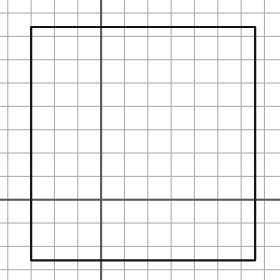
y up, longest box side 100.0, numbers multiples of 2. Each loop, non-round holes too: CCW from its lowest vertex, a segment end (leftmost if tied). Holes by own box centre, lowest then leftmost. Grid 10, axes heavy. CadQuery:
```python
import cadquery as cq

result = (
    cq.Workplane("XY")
    .moveTo(-30.0, -26.0)
    .lineTo(66.0, -26.0)
    .lineTo(66.0, 74.0)
    .lineTo(-30.0, 74.0)
    .close()
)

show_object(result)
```